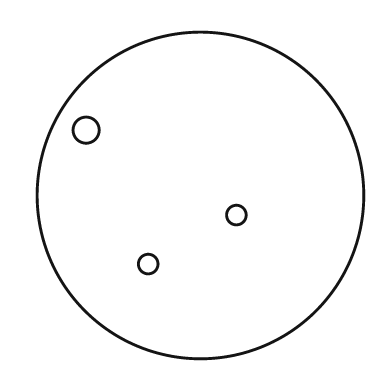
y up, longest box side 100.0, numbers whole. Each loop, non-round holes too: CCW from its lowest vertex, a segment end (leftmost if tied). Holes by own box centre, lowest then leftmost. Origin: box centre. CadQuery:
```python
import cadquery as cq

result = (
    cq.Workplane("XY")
    .moveTo(0.0, 0.0)
    .circle(50.0)
    .moveTo(-16.0, -21.0)
    .circle(3.0)
    .moveTo(11.0, -6.0)
    .circle(3.0)
    .moveTo(-35.0, 20.0)
    .circle(4.0)
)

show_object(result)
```